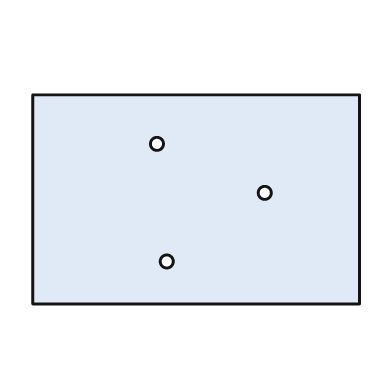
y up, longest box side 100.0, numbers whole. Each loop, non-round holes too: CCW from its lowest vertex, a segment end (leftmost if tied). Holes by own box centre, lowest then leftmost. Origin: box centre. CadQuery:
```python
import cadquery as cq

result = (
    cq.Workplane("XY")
    .moveTo(-50.0, -32.0)
    .lineTo(50.0, -32.0)
    .lineTo(50.0, 32.0)
    .lineTo(-50.0, 32.0)
    .close()
    .moveTo(-9.0, -19.0)
    .circle(2.0)
    .moveTo(21.0, 2.0)
    .circle(2.0)
    .moveTo(-12.0, 17.0)
    .circle(2.0)
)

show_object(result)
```